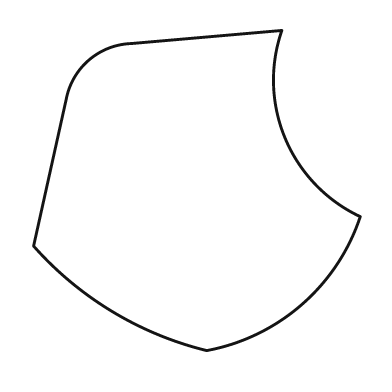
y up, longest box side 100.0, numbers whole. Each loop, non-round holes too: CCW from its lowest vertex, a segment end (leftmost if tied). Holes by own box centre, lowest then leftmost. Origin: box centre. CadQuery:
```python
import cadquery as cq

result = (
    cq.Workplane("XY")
    .moveTo(3.0, -49.0)
    .threePointArc((32.0, -35.0), (50.0, -8.0))
    .threePointArc((27.0, 16.0), (26.0, 49.0))
    .lineTo(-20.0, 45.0)
    .threePointArc((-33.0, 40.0), (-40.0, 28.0))
    .lineTo(-50.0, -17.0)
    .threePointArc((-26.0, -37.0), (3.0, -49.0))
    .close()
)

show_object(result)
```